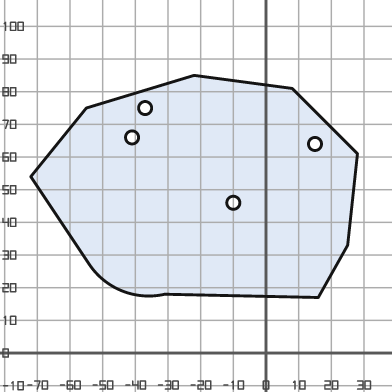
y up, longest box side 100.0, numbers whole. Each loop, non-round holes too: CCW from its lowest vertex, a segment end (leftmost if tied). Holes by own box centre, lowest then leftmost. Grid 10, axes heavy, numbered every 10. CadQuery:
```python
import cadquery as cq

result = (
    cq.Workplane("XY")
    .moveTo(16.0, 17.0)
    .lineTo(25.0, 33.0)
    .lineTo(28.0, 61.0)
    .lineTo(8.0, 81.0)
    .lineTo(-22.0, 85.0)
    .lineTo(-55.0, 75.0)
    .lineTo(-72.0, 54.0)
    .lineTo(-54.0, 27.0)
    .threePointArc((-44.0, 19.0), (-31.0, 18.0))
    .close()
    .moveTo(-10.0, 46.0)
    .circle(2.0)
    .moveTo(15.0, 64.0)
    .circle(2.0)
    .moveTo(-41.0, 66.0)
    .circle(2.0)
    .moveTo(-37.0, 75.0)
    .circle(2.0)
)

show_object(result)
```